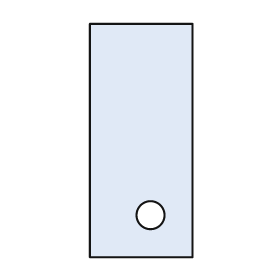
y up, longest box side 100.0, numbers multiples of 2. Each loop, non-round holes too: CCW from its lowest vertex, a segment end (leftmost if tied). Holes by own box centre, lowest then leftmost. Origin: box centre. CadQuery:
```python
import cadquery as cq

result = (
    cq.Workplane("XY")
    .moveTo(-22.0, -50.0)
    .lineTo(22.0, -50.0)
    .lineTo(22.0, 50.0)
    .lineTo(-22.0, 50.0)
    .close()
    .moveTo(4.0, -32.0)
    .circle(6.0)
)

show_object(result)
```